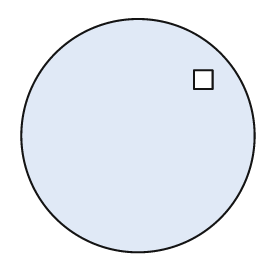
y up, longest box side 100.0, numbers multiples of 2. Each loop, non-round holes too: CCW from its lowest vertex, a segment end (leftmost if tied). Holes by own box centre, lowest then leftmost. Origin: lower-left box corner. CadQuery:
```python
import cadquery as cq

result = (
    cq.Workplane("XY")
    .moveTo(50.0, 50.0)
    .circle(50.0)
    .moveTo(74.0, 70.0)
    .lineTo(82.0, 70.0)
    .lineTo(82.0, 78.0)
    .lineTo(74.0, 78.0)
    .close()
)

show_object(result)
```